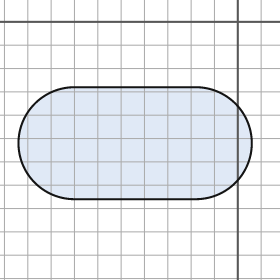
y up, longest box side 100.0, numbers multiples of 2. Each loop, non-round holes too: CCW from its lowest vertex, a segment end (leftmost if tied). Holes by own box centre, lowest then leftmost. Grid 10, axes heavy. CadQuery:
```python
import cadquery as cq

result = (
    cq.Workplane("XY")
    .moveTo(-70.0, -76.0)
    .lineTo(-18.0, -76.0)
    .threePointArc((6.0, -52.0), (-18.0, -28.0))
    .lineTo(-70.0, -28.0)
    .threePointArc((-94.0, -52.0), (-70.0, -76.0))
    .close()
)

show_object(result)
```